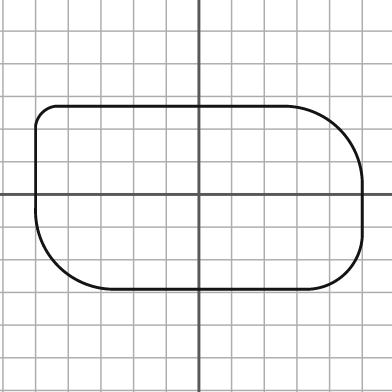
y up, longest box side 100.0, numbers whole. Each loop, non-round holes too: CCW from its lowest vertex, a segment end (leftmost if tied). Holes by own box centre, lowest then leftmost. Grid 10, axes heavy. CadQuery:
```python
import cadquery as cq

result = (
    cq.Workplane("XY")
    .moveTo(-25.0, -29.0)
    .lineTo(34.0, -29.0)
    .threePointArc((45.0, -24.0), (50.0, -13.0))
    .lineTo(50.0, 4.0)
    .threePointArc((43.0, 20.0), (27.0, 27.0))
    .lineTo(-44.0, 27.0)
    .threePointArc((-48.0, 25.0), (-50.0, 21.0))
    .lineTo(-50.0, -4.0)
    .threePointArc((-43.0, -22.0), (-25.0, -29.0))
    .close()
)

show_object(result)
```